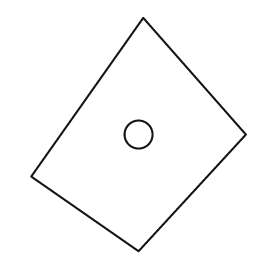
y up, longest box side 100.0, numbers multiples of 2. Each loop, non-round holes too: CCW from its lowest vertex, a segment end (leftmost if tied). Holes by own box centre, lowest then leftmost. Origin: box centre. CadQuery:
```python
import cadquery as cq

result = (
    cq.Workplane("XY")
    .moveTo(0.0, -50.0)
    .lineTo(46.0, 0.0)
    .lineTo(2.0, 50.0)
    .lineTo(-46.0, -18.0)
    .close()
    .moveTo(0.0, 0.0)
    .circle(6.0)
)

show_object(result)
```